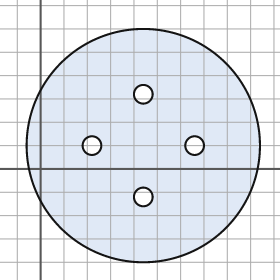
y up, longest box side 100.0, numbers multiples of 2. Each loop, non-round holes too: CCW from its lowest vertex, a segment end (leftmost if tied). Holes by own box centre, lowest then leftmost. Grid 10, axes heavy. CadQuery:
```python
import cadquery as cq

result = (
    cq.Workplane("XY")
    .moveTo(44.0, 10.0)
    .circle(50.0)
    .moveTo(44.0, -12.0)
    .circle(4.0)
    .moveTo(22.0, 10.0)
    .circle(4.0)
    .moveTo(66.0, 10.0)
    .circle(4.0)
    .moveTo(44.0, 32.0)
    .circle(4.0)
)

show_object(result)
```